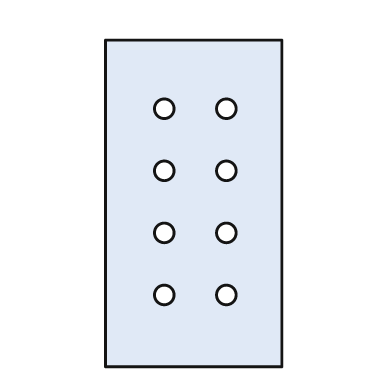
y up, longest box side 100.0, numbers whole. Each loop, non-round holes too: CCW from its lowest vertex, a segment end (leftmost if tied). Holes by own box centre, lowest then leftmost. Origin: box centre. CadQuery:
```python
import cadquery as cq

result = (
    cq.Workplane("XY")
    .moveTo(-27.0, -50.0)
    .lineTo(27.0, -50.0)
    .lineTo(27.0, 50.0)
    .lineTo(-27.0, 50.0)
    .close()
    .moveTo(-9.0, -28.0)
    .circle(3.0)
    .moveTo(10.0, -28.0)
    .circle(3.0)
    .moveTo(-9.0, -9.0)
    .circle(3.0)
    .moveTo(10.0, -9.0)
    .circle(3.0)
    .moveTo(-9.0, 10.0)
    .circle(3.0)
    .moveTo(10.0, 10.0)
    .circle(3.0)
    .moveTo(-9.0, 29.0)
    .circle(3.0)
    .moveTo(10.0, 29.0)
    .circle(3.0)
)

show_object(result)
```